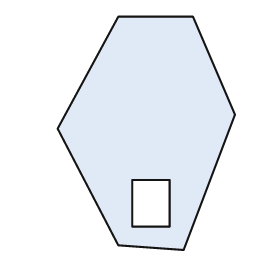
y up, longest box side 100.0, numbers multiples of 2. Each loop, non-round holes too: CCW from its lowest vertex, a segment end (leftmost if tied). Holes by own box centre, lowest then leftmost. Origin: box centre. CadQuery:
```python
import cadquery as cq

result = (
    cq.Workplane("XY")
    .moveTo(16.0, -50.0)
    .lineTo(38.0, 8.0)
    .lineTo(20.0, 50.0)
    .lineTo(-12.0, 50.0)
    .lineTo(-38.0, 2.0)
    .lineTo(-12.0, -48.0)
    .close()
    .moveTo(-6.0, -40.0)
    .lineTo(10.0, -40.0)
    .lineTo(10.0, -20.0)
    .lineTo(-6.0, -20.0)
    .close()
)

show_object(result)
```